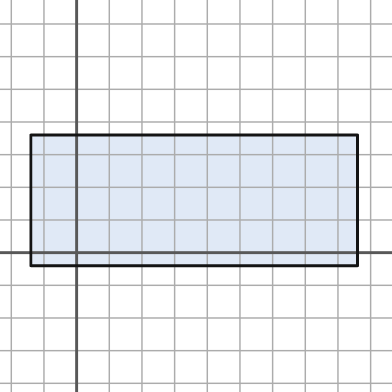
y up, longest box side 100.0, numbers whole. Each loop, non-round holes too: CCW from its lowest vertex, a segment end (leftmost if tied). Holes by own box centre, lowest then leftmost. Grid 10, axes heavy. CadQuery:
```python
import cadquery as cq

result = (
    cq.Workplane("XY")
    .moveTo(-14.0, -4.0)
    .lineTo(86.0, -4.0)
    .lineTo(86.0, 36.0)
    .lineTo(-14.0, 36.0)
    .close()
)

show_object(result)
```